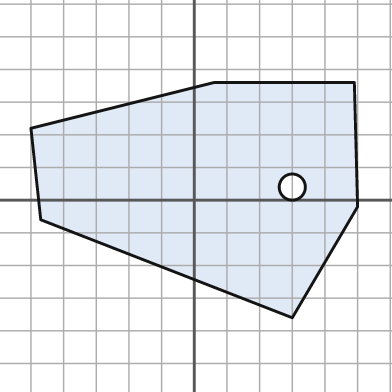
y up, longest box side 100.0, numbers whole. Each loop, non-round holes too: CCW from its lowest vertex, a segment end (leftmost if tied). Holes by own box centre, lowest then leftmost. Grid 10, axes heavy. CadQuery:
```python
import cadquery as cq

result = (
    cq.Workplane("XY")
    .moveTo(30.0, -36.0)
    .lineTo(50.0, -2.0)
    .lineTo(49.0, 36.0)
    .lineTo(6.0, 36.0)
    .lineTo(-50.0, 22.0)
    .lineTo(-47.0, -6.0)
    .close()
    .moveTo(30.0, 4.0)
    .circle(4.0)
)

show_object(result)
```